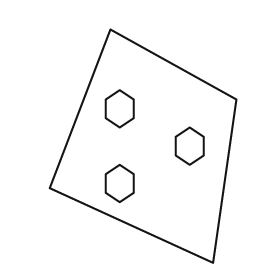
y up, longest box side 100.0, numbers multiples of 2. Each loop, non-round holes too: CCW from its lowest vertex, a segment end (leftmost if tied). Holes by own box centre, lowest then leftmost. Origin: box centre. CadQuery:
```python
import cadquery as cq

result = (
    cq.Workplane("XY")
    .moveTo(30.0, -50.0)
    .lineTo(40.0, 20.0)
    .lineTo(-14.0, 50.0)
    .lineTo(-40.0, -18.0)
    .close()
    .moveTo(-10.0, -24.0)
    .lineTo(-4.0, -20.0)
    .lineTo(-4.0, -12.0)
    .lineTo(-10.0, -8.0)
    .lineTo(-16.0, -12.0)
    .lineTo(-16.0, -20.0)
    .close()
    .moveTo(20.0, -8.0)
    .lineTo(26.0, -4.0)
    .lineTo(26.0, 4.0)
    .lineTo(20.0, 8.0)
    .lineTo(14.0, 4.0)
    .lineTo(14.0, -4.0)
    .close()
    .moveTo(-10.0, 8.0)
    .lineTo(-4.0, 12.0)
    .lineTo(-4.0, 20.0)
    .lineTo(-10.0, 24.0)
    .lineTo(-16.0, 20.0)
    .lineTo(-16.0, 12.0)
    .close()
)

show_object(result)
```